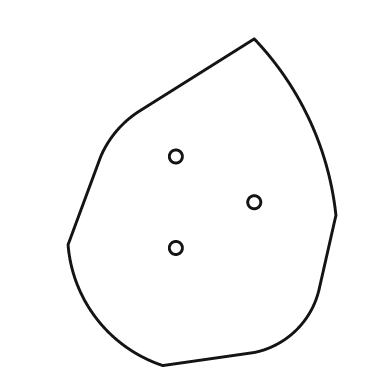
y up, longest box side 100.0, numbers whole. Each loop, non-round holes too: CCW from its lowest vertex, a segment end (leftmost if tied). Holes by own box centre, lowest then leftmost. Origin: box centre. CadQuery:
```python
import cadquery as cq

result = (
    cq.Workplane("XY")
    .moveTo(-12.0, -50.0)
    .lineTo(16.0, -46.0)
    .threePointArc((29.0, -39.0), (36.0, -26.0))
    .lineTo(41.0, -4.0)
    .threePointArc((33.0, 25.0), (16.0, 50.0))
    .lineTo(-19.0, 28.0)
    .threePointArc((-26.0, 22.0), (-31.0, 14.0))
    .lineTo(-41.0, -13.0)
    .threePointArc((-32.0, -36.0), (-12.0, -50.0))
    .close()
    .moveTo(-8.0, -14.0)
    .circle(2.0)
    .moveTo(16.0, 0.0)
    .circle(2.0)
    .moveTo(-8.0, 14.0)
    .circle(2.0)
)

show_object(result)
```